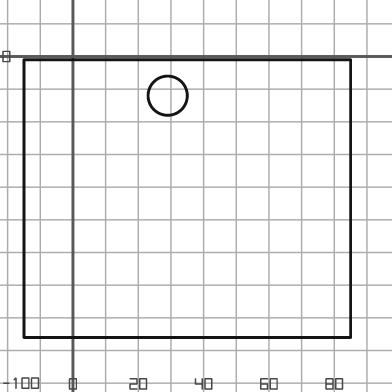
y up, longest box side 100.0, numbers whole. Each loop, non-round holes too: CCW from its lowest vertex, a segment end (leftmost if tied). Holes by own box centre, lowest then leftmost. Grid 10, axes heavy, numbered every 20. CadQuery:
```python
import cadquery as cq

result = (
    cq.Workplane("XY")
    .moveTo(-15.0, -86.0)
    .lineTo(85.0, -86.0)
    .lineTo(85.0, -1.0)
    .lineTo(-15.0, -1.0)
    .close()
    .moveTo(29.0, -12.0)
    .circle(6.0)
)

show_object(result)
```